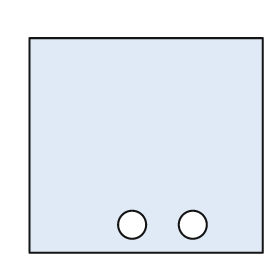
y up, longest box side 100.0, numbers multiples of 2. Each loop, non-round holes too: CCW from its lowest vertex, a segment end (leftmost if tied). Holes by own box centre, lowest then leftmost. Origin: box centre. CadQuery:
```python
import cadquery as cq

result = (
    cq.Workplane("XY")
    .moveTo(-50.0, -46.0)
    .lineTo(50.0, -46.0)
    .lineTo(50.0, 46.0)
    .lineTo(-50.0, 46.0)
    .close()
    .moveTo(-6.0, -34.0)
    .circle(6.0)
    .moveTo(20.0, -34.0)
    .circle(6.0)
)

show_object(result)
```